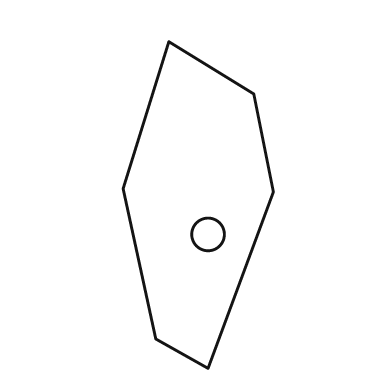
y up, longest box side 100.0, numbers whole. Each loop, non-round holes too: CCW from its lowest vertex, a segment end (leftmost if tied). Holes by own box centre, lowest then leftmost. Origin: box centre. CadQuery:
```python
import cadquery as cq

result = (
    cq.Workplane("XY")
    .moveTo(3.0, -50.0)
    .lineTo(23.0, 4.0)
    .lineTo(17.0, 34.0)
    .lineTo(-9.0, 50.0)
    .lineTo(-23.0, 5.0)
    .lineTo(-13.0, -41.0)
    .close()
    .moveTo(3.0, -9.0)
    .circle(5.0)
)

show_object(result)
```